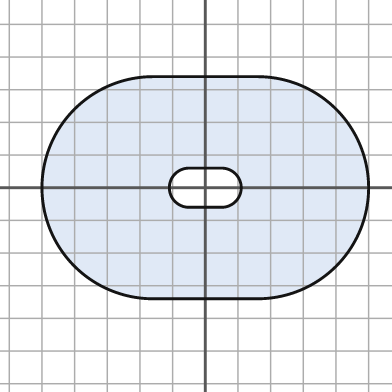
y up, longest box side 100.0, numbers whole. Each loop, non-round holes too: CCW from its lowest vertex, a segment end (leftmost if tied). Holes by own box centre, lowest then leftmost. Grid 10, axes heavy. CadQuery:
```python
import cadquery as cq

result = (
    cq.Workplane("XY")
    .moveTo(-16.0, -34.0)
    .lineTo(16.0, -34.0)
    .threePointArc((50.0, 0.0), (16.0, 34.0))
    .lineTo(-16.0, 34.0)
    .threePointArc((-50.0, 0.0), (-16.0, -34.0))
    .close()
    .moveTo(-5.0, -6.0)
    .lineTo(5.0, -6.0)
    .threePointArc((11.0, 0.0), (5.0, 6.0))
    .lineTo(-5.0, 6.0)
    .threePointArc((-11.0, 0.0), (-5.0, -6.0))
    .close()
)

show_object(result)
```